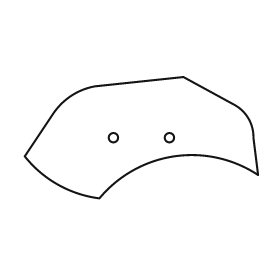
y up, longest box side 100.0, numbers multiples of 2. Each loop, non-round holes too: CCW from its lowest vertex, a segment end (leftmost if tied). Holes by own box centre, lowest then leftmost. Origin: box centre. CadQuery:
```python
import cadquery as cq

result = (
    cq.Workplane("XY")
    .moveTo(-18.0, -26.0)
    .threePointArc((14.0, -8.0), (50.0, -16.0))
    .lineTo(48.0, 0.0)
    .threePointArc((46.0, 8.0), (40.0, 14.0))
    .lineTo(18.0, 26.0)
    .lineTo(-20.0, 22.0)
    .threePointArc((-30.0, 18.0), (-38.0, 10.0))
    .lineTo(-50.0, -8.0)
    .threePointArc((-36.0, -20.0), (-18.0, -26.0))
    .close()
    .moveTo(-12.0, 0.0)
    .circle(2.0)
    .moveTo(12.0, 0.0)
    .circle(2.0)
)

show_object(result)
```